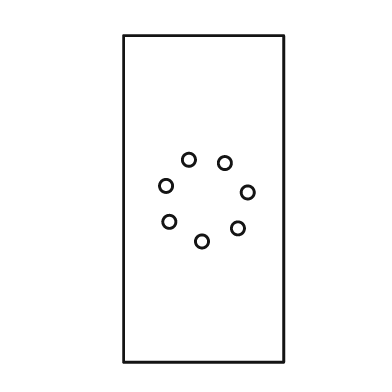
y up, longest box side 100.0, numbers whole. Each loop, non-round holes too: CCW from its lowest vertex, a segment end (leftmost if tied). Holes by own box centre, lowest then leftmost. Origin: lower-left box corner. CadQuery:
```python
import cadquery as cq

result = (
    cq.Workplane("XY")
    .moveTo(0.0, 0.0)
    .lineTo(49.0, 0.0)
    .lineTo(49.0, 100.0)
    .lineTo(0.0, 100.0)
    .close()
    .moveTo(24.0, 37.0)
    .circle(2.0)
    .moveTo(35.0, 41.0)
    .circle(2.0)
    .moveTo(14.0, 43.0)
    .circle(2.0)
    .moveTo(38.0, 52.0)
    .circle(2.0)
    .moveTo(13.0, 54.0)
    .circle(2.0)
    .moveTo(31.0, 61.0)
    .circle(2.0)
    .moveTo(20.0, 62.0)
    .circle(2.0)
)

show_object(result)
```